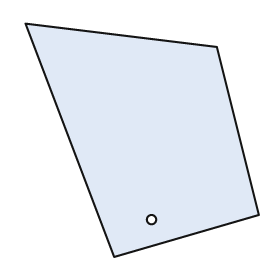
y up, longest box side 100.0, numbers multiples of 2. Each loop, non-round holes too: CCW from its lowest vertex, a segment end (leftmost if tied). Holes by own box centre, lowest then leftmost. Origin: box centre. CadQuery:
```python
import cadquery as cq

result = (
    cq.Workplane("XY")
    .moveTo(-12.0, -50.0)
    .lineTo(50.0, -32.0)
    .lineTo(32.0, 40.0)
    .lineTo(-50.0, 50.0)
    .close()
    .moveTo(4.0, -34.0)
    .circle(2.0)
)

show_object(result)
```